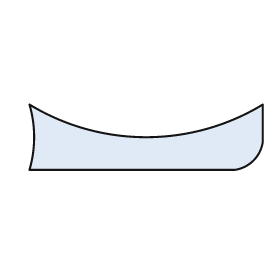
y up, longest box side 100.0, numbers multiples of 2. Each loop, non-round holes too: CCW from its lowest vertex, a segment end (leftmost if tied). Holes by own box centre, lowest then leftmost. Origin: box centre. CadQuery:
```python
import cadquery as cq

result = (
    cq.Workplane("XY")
    .moveTo(-50.0, -14.0)
    .lineTo(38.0, -14.0)
    .threePointArc((46.0, -10.0), (50.0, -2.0))
    .lineTo(50.0, 14.0)
    .threePointArc((0.0, 0.0), (-50.0, 14.0))
    .threePointArc((-48.0, 0.0), (-50.0, -14.0))
    .close()
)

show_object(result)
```